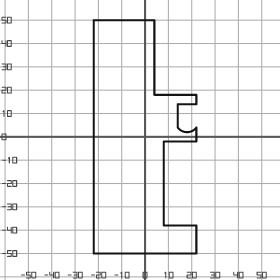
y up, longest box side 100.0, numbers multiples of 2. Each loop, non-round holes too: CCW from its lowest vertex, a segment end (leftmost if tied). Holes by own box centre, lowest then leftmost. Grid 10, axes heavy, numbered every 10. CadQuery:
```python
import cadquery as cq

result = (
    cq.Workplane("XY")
    .moveTo(-22.0, -50.0)
    .lineTo(22.0, -50.0)
    .lineTo(22.0, -38.0)
    .lineTo(8.0, -38.0)
    .lineTo(8.0, -2.0)
    .lineTo(22.0, -2.0)
    .lineTo(22.0, 4.0)
    .threePointArc((18.0, 2.0), (14.0, 4.0))
    .lineTo(14.0, 14.0)
    .lineTo(22.0, 14.0)
    .lineTo(22.0, 18.0)
    .lineTo(4.0, 18.0)
    .lineTo(4.0, 50.0)
    .lineTo(-22.0, 50.0)
    .close()
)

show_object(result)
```